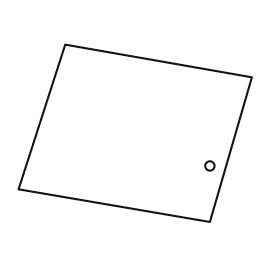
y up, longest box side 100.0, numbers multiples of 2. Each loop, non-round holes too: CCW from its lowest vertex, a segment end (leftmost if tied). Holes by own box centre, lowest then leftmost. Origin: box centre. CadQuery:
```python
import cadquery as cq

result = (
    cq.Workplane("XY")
    .moveTo(32.0, -38.0)
    .lineTo(50.0, 24.0)
    .lineTo(-30.0, 38.0)
    .lineTo(-50.0, -24.0)
    .close()
    .moveTo(32.0, -14.0)
    .circle(2.0)
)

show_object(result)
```